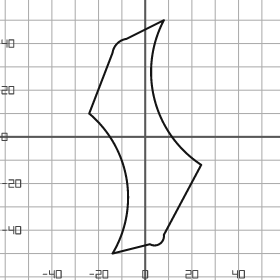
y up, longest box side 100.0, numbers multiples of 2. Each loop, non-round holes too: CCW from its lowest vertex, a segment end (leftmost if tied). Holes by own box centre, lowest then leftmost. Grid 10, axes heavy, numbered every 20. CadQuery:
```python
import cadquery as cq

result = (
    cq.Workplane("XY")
    .moveTo(-14.0, -50.0)
    .lineTo(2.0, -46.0)
    .threePointArc((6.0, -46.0), (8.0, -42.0))
    .lineTo(24.0, -12.0)
    .threePointArc((4.0, 16.0), (8.0, 50.0))
    .lineTo(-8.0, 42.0)
    .threePointArc((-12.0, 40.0), (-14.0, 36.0))
    .lineTo(-24.0, 10.0)
    .threePointArc((-8.0, -18.0), (-14.0, -50.0))
    .close()
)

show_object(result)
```